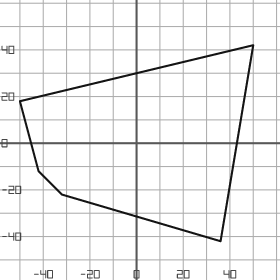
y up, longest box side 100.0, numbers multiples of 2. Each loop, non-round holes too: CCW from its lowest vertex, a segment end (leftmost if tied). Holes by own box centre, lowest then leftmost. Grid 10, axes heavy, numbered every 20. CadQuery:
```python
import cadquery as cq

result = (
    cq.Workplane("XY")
    .moveTo(36.0, -42.0)
    .lineTo(50.0, 42.0)
    .lineTo(-50.0, 18.0)
    .lineTo(-42.0, -12.0)
    .lineTo(-32.0, -22.0)
    .close()
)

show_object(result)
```